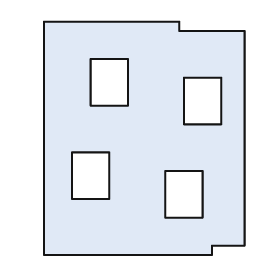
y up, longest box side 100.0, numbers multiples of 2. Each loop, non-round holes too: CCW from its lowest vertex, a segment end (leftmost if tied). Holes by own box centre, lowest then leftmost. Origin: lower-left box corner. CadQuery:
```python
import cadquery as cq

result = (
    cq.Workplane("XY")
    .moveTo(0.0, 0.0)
    .lineTo(72.0, 0.0)
    .lineTo(72.0, 4.0)
    .lineTo(86.0, 4.0)
    .lineTo(86.0, 96.0)
    .lineTo(58.0, 96.0)
    .lineTo(58.0, 100.0)
    .lineTo(0.0, 100.0)
    .close()
    .moveTo(52.0, 16.0)
    .lineTo(68.0, 16.0)
    .lineTo(68.0, 36.0)
    .lineTo(52.0, 36.0)
    .close()
    .moveTo(12.0, 24.0)
    .lineTo(28.0, 24.0)
    .lineTo(28.0, 44.0)
    .lineTo(12.0, 44.0)
    .close()
    .moveTo(60.0, 56.0)
    .lineTo(76.0, 56.0)
    .lineTo(76.0, 76.0)
    .lineTo(60.0, 76.0)
    .close()
    .moveTo(20.0, 64.0)
    .lineTo(36.0, 64.0)
    .lineTo(36.0, 84.0)
    .lineTo(20.0, 84.0)
    .close()
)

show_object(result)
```